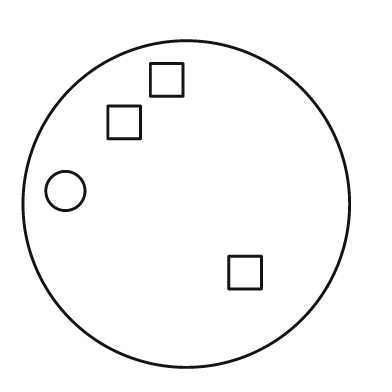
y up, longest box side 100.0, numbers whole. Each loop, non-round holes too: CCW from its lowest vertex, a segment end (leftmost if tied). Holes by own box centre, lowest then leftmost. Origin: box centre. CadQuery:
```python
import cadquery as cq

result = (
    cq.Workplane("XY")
    .moveTo(0.0, 0.0)
    .circle(50.0)
    .moveTo(13.0, -26.0)
    .lineTo(23.0, -26.0)
    .lineTo(23.0, -16.0)
    .lineTo(13.0, -16.0)
    .close()
    .moveTo(-37.0, 4.0)
    .circle(6.0)
    .moveTo(-24.0, 20.0)
    .lineTo(-14.0, 20.0)
    .lineTo(-14.0, 30.0)
    .lineTo(-24.0, 30.0)
    .close()
    .moveTo(-11.0, 33.0)
    .lineTo(-1.0, 33.0)
    .lineTo(-1.0, 43.0)
    .lineTo(-11.0, 43.0)
    .close()
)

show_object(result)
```